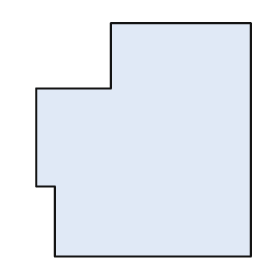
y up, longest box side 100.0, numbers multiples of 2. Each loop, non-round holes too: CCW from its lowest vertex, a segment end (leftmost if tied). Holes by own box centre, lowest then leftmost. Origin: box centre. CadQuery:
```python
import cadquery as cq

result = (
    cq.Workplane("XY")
    .moveTo(-38.0, -50.0)
    .lineTo(46.0, -50.0)
    .lineTo(46.0, 50.0)
    .lineTo(-14.0, 50.0)
    .lineTo(-14.0, 22.0)
    .lineTo(-46.0, 22.0)
    .lineTo(-46.0, -20.0)
    .lineTo(-38.0, -20.0)
    .close()
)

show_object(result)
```